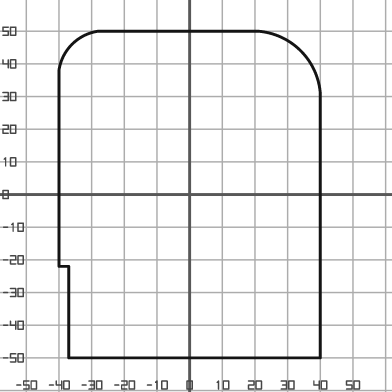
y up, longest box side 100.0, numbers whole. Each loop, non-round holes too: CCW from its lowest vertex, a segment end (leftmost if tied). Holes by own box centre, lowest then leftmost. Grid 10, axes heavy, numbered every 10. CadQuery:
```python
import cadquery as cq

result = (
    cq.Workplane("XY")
    .moveTo(-37.0, -50.0)
    .lineTo(40.0, -50.0)
    .lineTo(40.0, 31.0)
    .threePointArc((34.0, 44.0), (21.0, 50.0))
    .lineTo(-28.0, 50.0)
    .threePointArc((-36.0, 46.0), (-40.0, 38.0))
    .lineTo(-40.0, -22.0)
    .lineTo(-37.0, -22.0)
    .close()
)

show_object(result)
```